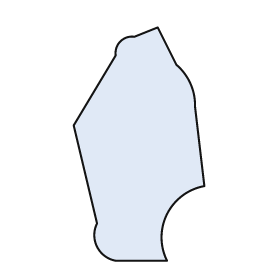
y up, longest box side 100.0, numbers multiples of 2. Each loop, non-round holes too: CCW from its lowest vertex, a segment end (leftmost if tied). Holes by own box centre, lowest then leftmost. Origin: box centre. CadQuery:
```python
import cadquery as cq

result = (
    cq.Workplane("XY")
    .moveTo(-10.0, -50.0)
    .lineTo(12.0, -50.0)
    .threePointArc((12.0, -30.0), (28.0, -18.0))
    .lineTo(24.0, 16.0)
    .threePointArc((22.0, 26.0), (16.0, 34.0))
    .lineTo(8.0, 50.0)
    .lineTo(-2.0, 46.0)
    .threePointArc((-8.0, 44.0), (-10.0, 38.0))
    .lineTo(-28.0, 8.0)
    .lineTo(-18.0, -34.0)
    .threePointArc((-18.0, -44.0), (-10.0, -50.0))
    .close()
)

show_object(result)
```